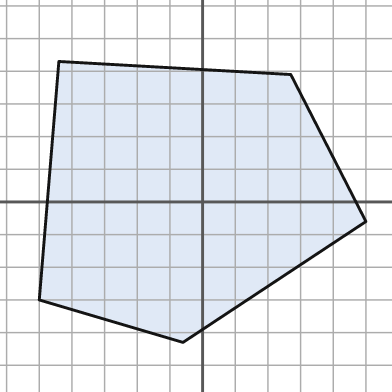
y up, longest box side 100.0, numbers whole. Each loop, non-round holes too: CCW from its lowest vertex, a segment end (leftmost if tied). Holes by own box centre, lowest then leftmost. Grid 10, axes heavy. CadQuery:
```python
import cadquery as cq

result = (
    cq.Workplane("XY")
    .moveTo(-6.0, -43.0)
    .lineTo(50.0, -6.0)
    .lineTo(27.0, 39.0)
    .lineTo(-44.0, 43.0)
    .lineTo(-50.0, -30.0)
    .close()
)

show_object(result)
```